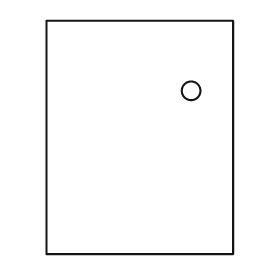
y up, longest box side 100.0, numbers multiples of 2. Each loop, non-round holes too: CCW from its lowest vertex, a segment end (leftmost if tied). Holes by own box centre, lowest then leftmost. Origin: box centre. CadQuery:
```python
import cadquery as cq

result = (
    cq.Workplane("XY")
    .moveTo(-40.0, -50.0)
    .lineTo(40.0, -50.0)
    .lineTo(40.0, 50.0)
    .lineTo(-40.0, 50.0)
    .close()
    .moveTo(22.0, 20.0)
    .circle(4.0)
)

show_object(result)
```